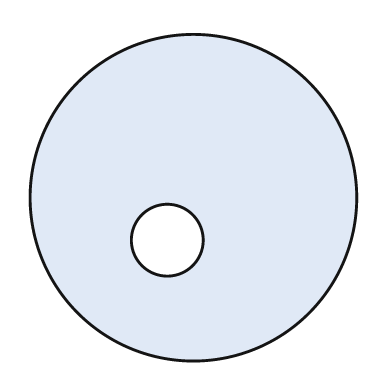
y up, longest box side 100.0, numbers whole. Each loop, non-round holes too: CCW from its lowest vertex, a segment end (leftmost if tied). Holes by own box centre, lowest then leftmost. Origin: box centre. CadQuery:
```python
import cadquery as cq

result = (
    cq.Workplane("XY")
    .moveTo(0.0, 0.0)
    .circle(50.0)
    .moveTo(-8.0, -13.0)
    .circle(11.0)
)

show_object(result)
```